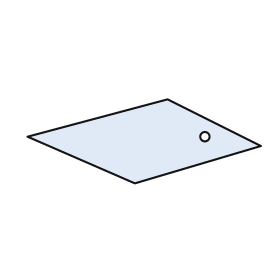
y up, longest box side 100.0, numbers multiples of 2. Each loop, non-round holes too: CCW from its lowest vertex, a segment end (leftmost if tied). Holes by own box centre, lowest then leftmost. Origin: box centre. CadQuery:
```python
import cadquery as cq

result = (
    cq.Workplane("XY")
    .moveTo(-4.0, -18.0)
    .lineTo(50.0, -2.0)
    .lineTo(10.0, 18.0)
    .lineTo(-50.0, 2.0)
    .close()
    .moveTo(26.0, 2.0)
    .circle(2.0)
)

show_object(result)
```